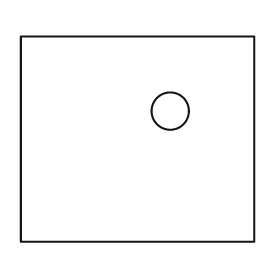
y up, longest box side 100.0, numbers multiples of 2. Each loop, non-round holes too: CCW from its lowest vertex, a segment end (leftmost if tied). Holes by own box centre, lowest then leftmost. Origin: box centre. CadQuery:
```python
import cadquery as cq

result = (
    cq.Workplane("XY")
    .moveTo(-50.0, -44.0)
    .lineTo(50.0, -44.0)
    .lineTo(50.0, 44.0)
    .lineTo(-50.0, 44.0)
    .close()
    .moveTo(14.0, 12.0)
    .circle(8.0)
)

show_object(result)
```